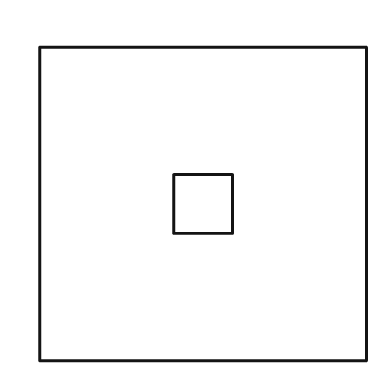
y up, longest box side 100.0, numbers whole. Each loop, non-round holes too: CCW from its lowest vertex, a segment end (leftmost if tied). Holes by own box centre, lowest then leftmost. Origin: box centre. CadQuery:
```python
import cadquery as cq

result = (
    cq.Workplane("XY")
    .moveTo(-50.0, -48.0)
    .lineTo(50.0, -48.0)
    .lineTo(50.0, 48.0)
    .lineTo(-50.0, 48.0)
    .close()
    .moveTo(-9.0, -9.0)
    .lineTo(9.0, -9.0)
    .lineTo(9.0, 9.0)
    .lineTo(-9.0, 9.0)
    .close()
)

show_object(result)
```